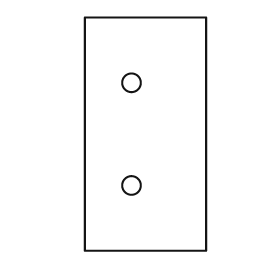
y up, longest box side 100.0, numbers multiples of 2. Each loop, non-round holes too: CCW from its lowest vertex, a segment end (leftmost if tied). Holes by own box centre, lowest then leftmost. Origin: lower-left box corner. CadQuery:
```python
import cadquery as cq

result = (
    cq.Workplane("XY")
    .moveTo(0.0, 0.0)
    .lineTo(52.0, 0.0)
    .lineTo(52.0, 100.0)
    .lineTo(0.0, 100.0)
    .close()
    .moveTo(20.0, 28.0)
    .circle(4.0)
    .moveTo(20.0, 72.0)
    .circle(4.0)
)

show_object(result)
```